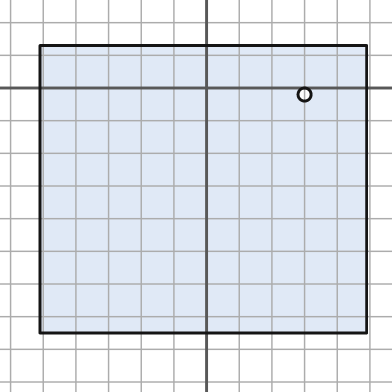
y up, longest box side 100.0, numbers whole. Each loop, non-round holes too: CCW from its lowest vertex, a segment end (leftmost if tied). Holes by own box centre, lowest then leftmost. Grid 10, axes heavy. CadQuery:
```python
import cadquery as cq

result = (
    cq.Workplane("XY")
    .moveTo(-51.0, -75.0)
    .lineTo(49.0, -75.0)
    .lineTo(49.0, 13.0)
    .lineTo(-51.0, 13.0)
    .close()
    .moveTo(30.0, -2.0)
    .circle(2.0)
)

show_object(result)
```